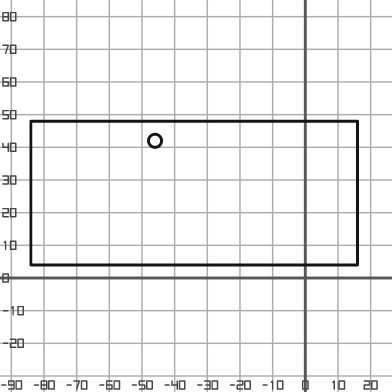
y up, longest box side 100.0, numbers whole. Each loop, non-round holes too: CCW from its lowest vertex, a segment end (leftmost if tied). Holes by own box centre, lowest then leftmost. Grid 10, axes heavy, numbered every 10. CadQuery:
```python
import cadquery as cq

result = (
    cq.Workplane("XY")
    .moveTo(-84.0, 4.0)
    .lineTo(16.0, 4.0)
    .lineTo(16.0, 48.0)
    .lineTo(-84.0, 48.0)
    .close()
    .moveTo(-46.0, 42.0)
    .circle(2.0)
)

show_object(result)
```